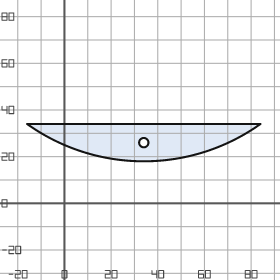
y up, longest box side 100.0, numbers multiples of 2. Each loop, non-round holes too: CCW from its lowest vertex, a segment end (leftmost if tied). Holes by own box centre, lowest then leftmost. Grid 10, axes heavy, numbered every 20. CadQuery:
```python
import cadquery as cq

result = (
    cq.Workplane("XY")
    .moveTo(-16.0, 34.0)
    .threePointArc((34.0, 18.0), (84.0, 34.0))
    .close()
    .moveTo(34.0, 26.0)
    .circle(2.0)
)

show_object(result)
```